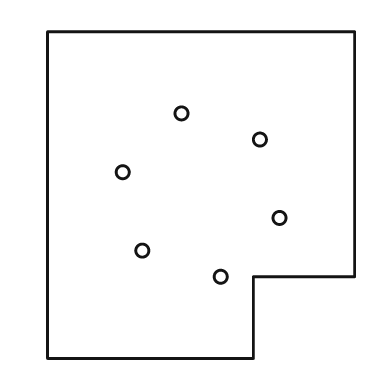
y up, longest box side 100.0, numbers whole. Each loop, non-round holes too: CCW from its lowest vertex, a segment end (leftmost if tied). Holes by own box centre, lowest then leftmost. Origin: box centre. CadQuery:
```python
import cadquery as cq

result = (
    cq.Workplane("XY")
    .moveTo(-47.0, -50.0)
    .lineTo(16.0, -50.0)
    .lineTo(16.0, -25.0)
    .lineTo(47.0, -25.0)
    .lineTo(47.0, 50.0)
    .lineTo(-47.0, 50.0)
    .close()
    .moveTo(6.0, -25.0)
    .circle(2.0)
    .moveTo(-18.0, -17.0)
    .circle(2.0)
    .moveTo(24.0, -7.0)
    .circle(2.0)
    .moveTo(-24.0, 7.0)
    .circle(2.0)
    .moveTo(18.0, 17.0)
    .circle(2.0)
    .moveTo(-6.0, 25.0)
    .circle(2.0)
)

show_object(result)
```